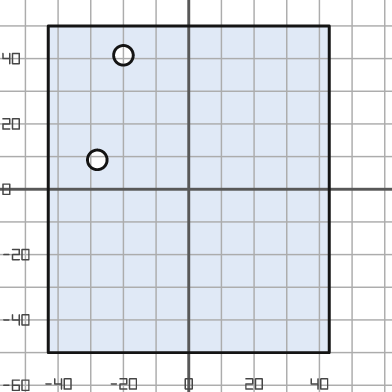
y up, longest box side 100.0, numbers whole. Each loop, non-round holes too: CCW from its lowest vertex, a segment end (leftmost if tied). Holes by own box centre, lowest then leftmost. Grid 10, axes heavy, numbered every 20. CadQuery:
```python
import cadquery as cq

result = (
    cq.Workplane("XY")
    .moveTo(-43.0, -50.0)
    .lineTo(43.0, -50.0)
    .lineTo(43.0, 50.0)
    .lineTo(-43.0, 50.0)
    .close()
    .moveTo(-28.0, 9.0)
    .circle(3.0)
    .moveTo(-20.0, 41.0)
    .circle(3.0)
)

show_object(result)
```